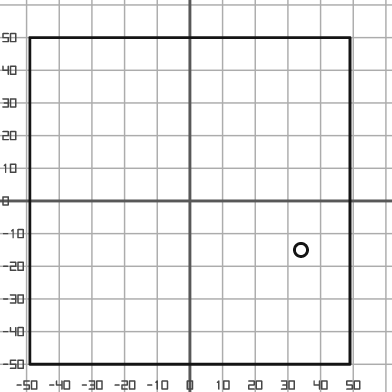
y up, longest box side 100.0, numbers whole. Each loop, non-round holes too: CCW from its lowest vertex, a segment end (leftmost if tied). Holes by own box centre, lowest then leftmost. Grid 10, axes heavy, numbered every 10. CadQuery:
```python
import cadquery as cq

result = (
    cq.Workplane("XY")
    .moveTo(-49.0, -50.0)
    .lineTo(49.0, -50.0)
    .lineTo(49.0, 50.0)
    .lineTo(-49.0, 50.0)
    .close()
    .moveTo(34.0, -15.0)
    .circle(2.0)
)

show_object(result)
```